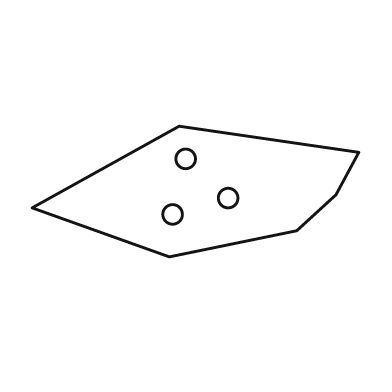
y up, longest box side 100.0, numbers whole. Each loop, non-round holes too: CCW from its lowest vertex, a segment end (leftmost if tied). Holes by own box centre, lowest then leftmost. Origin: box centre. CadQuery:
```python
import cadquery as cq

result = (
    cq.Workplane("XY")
    .moveTo(-8.0, -20.0)
    .lineTo(31.0, -12.0)
    .lineTo(43.0, -1.0)
    .lineTo(50.0, 12.0)
    .lineTo(-5.0, 20.0)
    .lineTo(-50.0, -5.0)
    .close()
    .moveTo(-7.0, -7.0)
    .circle(3.0)
    .moveTo(10.0, -2.0)
    .circle(3.0)
    .moveTo(-3.0, 10.0)
    .circle(3.0)
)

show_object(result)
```